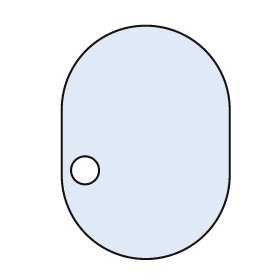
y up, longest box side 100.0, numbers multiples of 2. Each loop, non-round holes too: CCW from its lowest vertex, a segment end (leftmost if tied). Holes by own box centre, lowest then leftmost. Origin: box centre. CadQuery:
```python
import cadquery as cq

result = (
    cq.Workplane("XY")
    .moveTo(-36.0, -14.0)
    .threePointArc((0.0, -50.0), (36.0, -14.0))
    .lineTo(36.0, 14.0)
    .threePointArc((0.0, 50.0), (-36.0, 14.0))
    .close()
    .moveTo(-26.0, -12.0)
    .circle(6.0)
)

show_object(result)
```